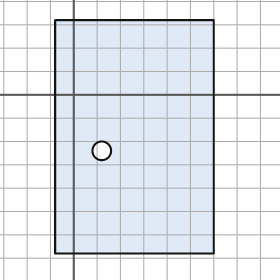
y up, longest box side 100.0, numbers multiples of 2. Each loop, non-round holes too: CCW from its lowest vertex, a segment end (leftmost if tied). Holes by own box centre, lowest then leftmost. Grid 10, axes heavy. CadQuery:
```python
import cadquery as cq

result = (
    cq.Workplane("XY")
    .moveTo(-8.0, -68.0)
    .lineTo(60.0, -68.0)
    .lineTo(60.0, 32.0)
    .lineTo(-8.0, 32.0)
    .close()
    .moveTo(12.0, -24.0)
    .circle(4.0)
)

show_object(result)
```